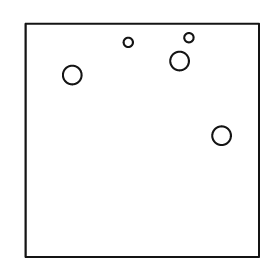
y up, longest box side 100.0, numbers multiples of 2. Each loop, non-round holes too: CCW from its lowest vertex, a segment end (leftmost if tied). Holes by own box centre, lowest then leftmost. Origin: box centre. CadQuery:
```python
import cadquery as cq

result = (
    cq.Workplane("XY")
    .moveTo(-50.0, -50.0)
    .lineTo(50.0, -50.0)
    .lineTo(50.0, 50.0)
    .lineTo(-50.0, 50.0)
    .close()
    .moveTo(34.0, 2.0)
    .circle(4.0)
    .moveTo(-30.0, 28.0)
    .circle(4.0)
    .moveTo(16.0, 34.0)
    .circle(4.0)
    .moveTo(-6.0, 42.0)
    .circle(2.0)
    .moveTo(20.0, 44.0)
    .circle(2.0)
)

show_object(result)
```